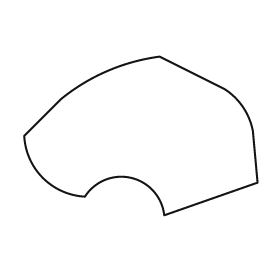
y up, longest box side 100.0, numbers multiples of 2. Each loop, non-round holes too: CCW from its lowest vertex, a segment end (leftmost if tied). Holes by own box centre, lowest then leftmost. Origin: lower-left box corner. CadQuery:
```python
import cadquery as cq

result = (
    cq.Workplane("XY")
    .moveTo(60.0, 0.0)
    .lineTo(100.0, 14.0)
    .lineTo(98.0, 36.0)
    .threePointArc((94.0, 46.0), (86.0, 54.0))
    .lineTo(58.0, 68.0)
    .threePointArc((36.0, 62.0), (16.0, 50.0))
    .lineTo(0.0, 34.0)
    .threePointArc((8.0, 16.0), (26.0, 8.0))
    .threePointArc((46.0, 16.0), (60.0, 0.0))
    .close()
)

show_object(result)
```